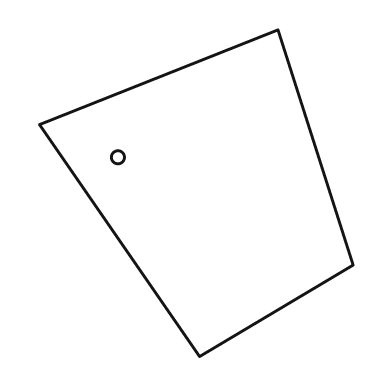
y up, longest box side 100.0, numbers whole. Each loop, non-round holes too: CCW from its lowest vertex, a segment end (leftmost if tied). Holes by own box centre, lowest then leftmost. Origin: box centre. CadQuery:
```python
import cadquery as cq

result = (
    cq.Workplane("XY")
    .moveTo(1.0, -50.0)
    .lineTo(48.0, -22.0)
    .lineTo(25.0, 50.0)
    .lineTo(-48.0, 21.0)
    .close()
    .moveTo(-24.0, 11.0)
    .circle(2.0)
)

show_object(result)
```